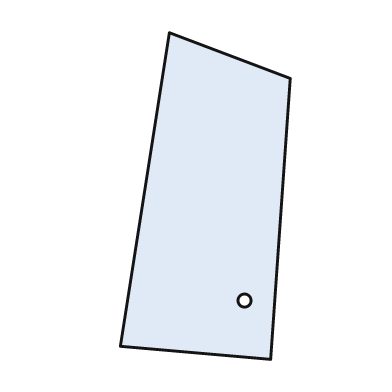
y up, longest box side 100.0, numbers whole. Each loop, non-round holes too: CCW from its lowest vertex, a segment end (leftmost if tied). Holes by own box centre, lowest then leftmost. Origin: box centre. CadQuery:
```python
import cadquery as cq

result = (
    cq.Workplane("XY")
    .moveTo(20.0, -50.0)
    .lineTo(26.0, 36.0)
    .lineTo(-11.0, 50.0)
    .lineTo(-26.0, -46.0)
    .close()
    .moveTo(12.0, -32.0)
    .circle(2.0)
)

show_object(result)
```